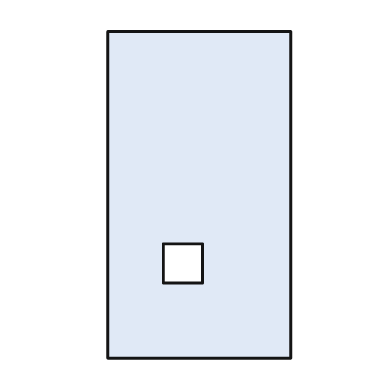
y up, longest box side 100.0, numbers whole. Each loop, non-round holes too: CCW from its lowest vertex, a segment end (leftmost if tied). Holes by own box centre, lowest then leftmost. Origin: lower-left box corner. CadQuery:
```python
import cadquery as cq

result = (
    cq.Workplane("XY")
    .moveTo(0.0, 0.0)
    .lineTo(56.0, 0.0)
    .lineTo(56.0, 100.0)
    .lineTo(0.0, 100.0)
    .close()
    .moveTo(17.0, 23.0)
    .lineTo(29.0, 23.0)
    .lineTo(29.0, 35.0)
    .lineTo(17.0, 35.0)
    .close()
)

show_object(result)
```